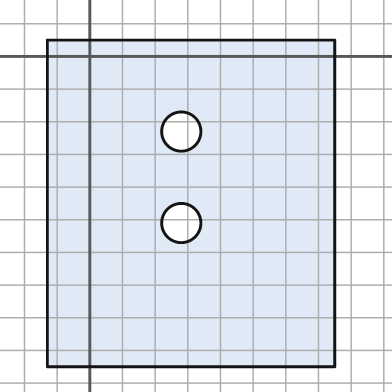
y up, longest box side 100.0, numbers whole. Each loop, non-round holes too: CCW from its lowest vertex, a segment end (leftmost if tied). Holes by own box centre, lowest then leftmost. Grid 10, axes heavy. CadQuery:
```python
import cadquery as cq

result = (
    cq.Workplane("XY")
    .moveTo(-13.0, -95.0)
    .lineTo(75.0, -95.0)
    .lineTo(75.0, 5.0)
    .lineTo(-13.0, 5.0)
    .close()
    .moveTo(28.0, -51.0)
    .circle(6.0)
    .moveTo(28.0, -23.0)
    .circle(6.0)
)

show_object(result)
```